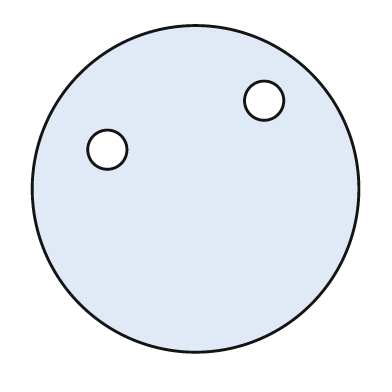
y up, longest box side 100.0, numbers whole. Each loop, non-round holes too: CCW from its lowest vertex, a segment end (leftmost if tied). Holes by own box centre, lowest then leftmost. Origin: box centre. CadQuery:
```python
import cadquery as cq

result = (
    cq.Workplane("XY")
    .moveTo(0.0, 0.0)
    .circle(50.0)
    .moveTo(-27.0, 12.0)
    .circle(6.0)
    .moveTo(21.0, 27.0)
    .circle(6.0)
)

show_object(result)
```